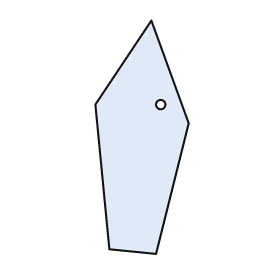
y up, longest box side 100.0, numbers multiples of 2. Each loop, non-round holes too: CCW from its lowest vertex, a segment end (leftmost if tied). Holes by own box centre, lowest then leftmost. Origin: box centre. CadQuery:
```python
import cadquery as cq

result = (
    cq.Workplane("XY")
    .moveTo(6.0, -50.0)
    .lineTo(20.0, 6.0)
    .lineTo(4.0, 50.0)
    .lineTo(-20.0, 14.0)
    .lineTo(-14.0, -48.0)
    .close()
    .moveTo(8.0, 14.0)
    .circle(2.0)
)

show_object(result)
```